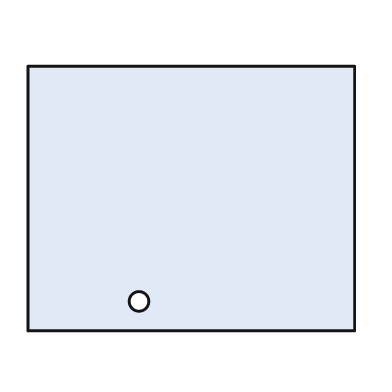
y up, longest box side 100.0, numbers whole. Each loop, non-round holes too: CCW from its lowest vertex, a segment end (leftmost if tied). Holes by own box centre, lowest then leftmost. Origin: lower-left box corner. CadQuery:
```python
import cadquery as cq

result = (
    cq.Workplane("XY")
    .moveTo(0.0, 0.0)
    .lineTo(100.0, 0.0)
    .lineTo(100.0, 81.0)
    .lineTo(0.0, 81.0)
    .close()
    .moveTo(34.0, 9.0)
    .circle(3.0)
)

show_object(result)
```